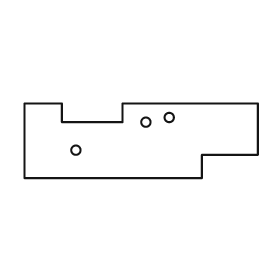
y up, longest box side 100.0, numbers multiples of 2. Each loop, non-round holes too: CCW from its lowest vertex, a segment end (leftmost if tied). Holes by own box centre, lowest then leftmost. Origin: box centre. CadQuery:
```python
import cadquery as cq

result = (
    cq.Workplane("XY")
    .moveTo(-50.0, -16.0)
    .lineTo(26.0, -16.0)
    .lineTo(26.0, -6.0)
    .lineTo(50.0, -6.0)
    .lineTo(50.0, 16.0)
    .lineTo(-8.0, 16.0)
    .lineTo(-8.0, 8.0)
    .lineTo(-34.0, 8.0)
    .lineTo(-34.0, 16.0)
    .lineTo(-50.0, 16.0)
    .close()
    .moveTo(-28.0, -4.0)
    .circle(2.0)
    .moveTo(2.0, 8.0)
    .circle(2.0)
    .moveTo(12.0, 10.0)
    .circle(2.0)
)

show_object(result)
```